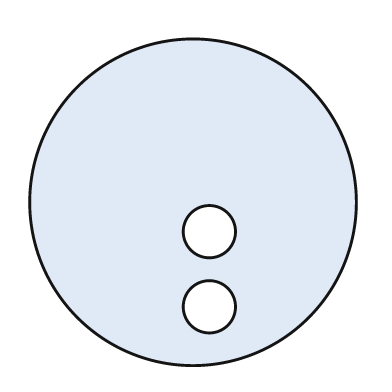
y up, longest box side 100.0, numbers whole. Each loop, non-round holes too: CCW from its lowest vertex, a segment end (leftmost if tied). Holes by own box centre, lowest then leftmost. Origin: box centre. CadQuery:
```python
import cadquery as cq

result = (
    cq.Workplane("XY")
    .moveTo(0.0, 0.0)
    .circle(50.0)
    .moveTo(5.0, -32.0)
    .circle(8.0)
    .moveTo(5.0, -9.0)
    .circle(8.0)
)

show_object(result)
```